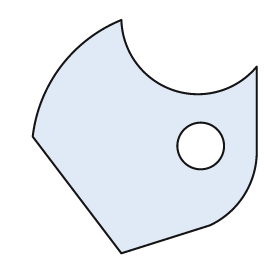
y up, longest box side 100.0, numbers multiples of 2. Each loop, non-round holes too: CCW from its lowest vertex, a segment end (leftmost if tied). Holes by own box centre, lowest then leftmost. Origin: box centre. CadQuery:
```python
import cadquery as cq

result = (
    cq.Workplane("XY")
    .moveTo(-10.0, -50.0)
    .lineTo(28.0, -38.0)
    .threePointArc((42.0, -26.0), (48.0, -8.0))
    .lineTo(48.0, 30.0)
    .threePointArc((12.0, 20.0), (-10.0, 50.0))
    .threePointArc((-36.0, 30.0), (-48.0, 0.0))
    .close()
    .moveTo(24.0, -4.0)
    .circle(10.0)
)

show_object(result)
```